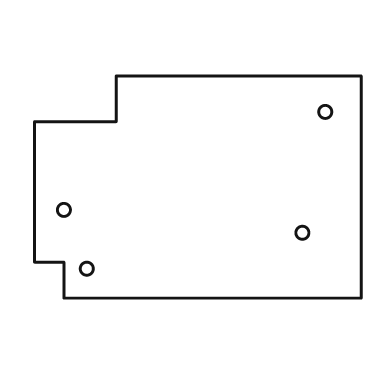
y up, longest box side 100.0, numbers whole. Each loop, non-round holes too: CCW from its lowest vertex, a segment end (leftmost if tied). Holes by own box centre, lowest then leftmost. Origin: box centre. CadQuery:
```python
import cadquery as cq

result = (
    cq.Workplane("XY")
    .moveTo(-41.0, -34.0)
    .lineTo(50.0, -34.0)
    .lineTo(50.0, 34.0)
    .lineTo(-25.0, 34.0)
    .lineTo(-25.0, 20.0)
    .lineTo(-50.0, 20.0)
    .lineTo(-50.0, -23.0)
    .lineTo(-41.0, -23.0)
    .close()
    .moveTo(-34.0, -25.0)
    .circle(2.0)
    .moveTo(32.0, -14.0)
    .circle(2.0)
    .moveTo(-41.0, -7.0)
    .circle(2.0)
    .moveTo(39.0, 23.0)
    .circle(2.0)
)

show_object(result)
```